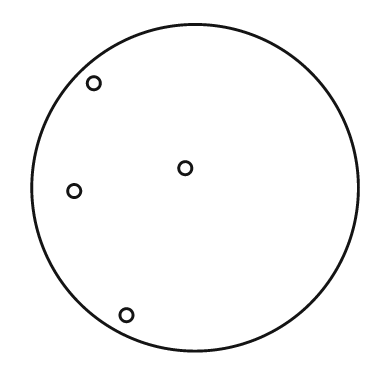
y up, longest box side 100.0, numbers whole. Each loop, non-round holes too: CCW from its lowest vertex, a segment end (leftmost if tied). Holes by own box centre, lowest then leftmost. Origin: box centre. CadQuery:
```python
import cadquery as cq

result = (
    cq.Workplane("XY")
    .moveTo(0.0, 0.0)
    .circle(50.0)
    .moveTo(-21.0, -39.0)
    .circle(2.0)
    .moveTo(-37.0, -1.0)
    .circle(2.0)
    .moveTo(-3.0, 6.0)
    .circle(2.0)
    .moveTo(-31.0, 32.0)
    .circle(2.0)
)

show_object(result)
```